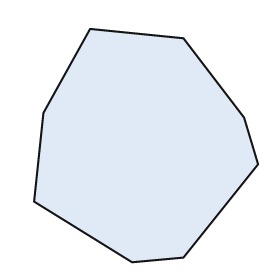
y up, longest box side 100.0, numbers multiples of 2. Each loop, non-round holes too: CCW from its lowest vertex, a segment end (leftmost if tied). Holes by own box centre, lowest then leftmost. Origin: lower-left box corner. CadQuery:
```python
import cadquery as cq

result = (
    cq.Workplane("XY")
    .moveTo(42.0, 0.0)
    .lineTo(64.0, 2.0)
    .lineTo(96.0, 42.0)
    .lineTo(90.0, 62.0)
    .lineTo(64.0, 96.0)
    .lineTo(24.0, 100.0)
    .lineTo(4.0, 64.0)
    .lineTo(0.0, 26.0)
    .close()
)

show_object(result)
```